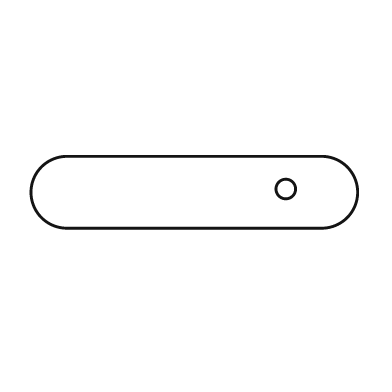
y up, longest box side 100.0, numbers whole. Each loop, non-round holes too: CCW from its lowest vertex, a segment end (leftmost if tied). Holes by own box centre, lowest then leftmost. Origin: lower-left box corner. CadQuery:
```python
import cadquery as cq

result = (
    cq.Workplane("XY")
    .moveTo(11.0, 0.0)
    .lineTo(89.0, 0.0)
    .threePointArc((100.0, 11.0), (89.0, 22.0))
    .lineTo(11.0, 22.0)
    .threePointArc((0.0, 11.0), (11.0, 0.0))
    .close()
    .moveTo(78.0, 12.0)
    .circle(3.0)
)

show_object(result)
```